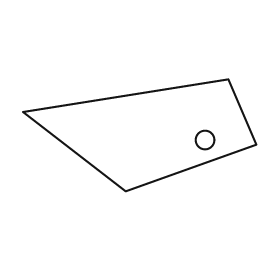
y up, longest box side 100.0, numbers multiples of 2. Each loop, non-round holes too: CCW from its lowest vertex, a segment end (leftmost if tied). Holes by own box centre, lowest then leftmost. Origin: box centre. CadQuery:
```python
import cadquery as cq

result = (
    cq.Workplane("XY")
    .moveTo(-6.0, -24.0)
    .lineTo(50.0, -4.0)
    .lineTo(38.0, 24.0)
    .lineTo(-50.0, 10.0)
    .close()
    .moveTo(28.0, -2.0)
    .circle(4.0)
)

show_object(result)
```